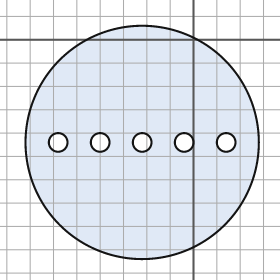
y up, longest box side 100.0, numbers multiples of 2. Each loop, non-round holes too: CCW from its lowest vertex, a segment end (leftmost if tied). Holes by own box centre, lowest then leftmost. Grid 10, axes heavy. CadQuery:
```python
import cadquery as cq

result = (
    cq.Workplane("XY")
    .moveTo(-22.0, -44.0)
    .circle(50.0)
    .moveTo(-58.0, -44.0)
    .circle(4.0)
    .moveTo(-40.0, -44.0)
    .circle(4.0)
    .moveTo(-22.0, -44.0)
    .circle(4.0)
    .moveTo(-4.0, -44.0)
    .circle(4.0)
    .moveTo(14.0, -44.0)
    .circle(4.0)
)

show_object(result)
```